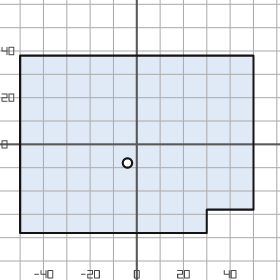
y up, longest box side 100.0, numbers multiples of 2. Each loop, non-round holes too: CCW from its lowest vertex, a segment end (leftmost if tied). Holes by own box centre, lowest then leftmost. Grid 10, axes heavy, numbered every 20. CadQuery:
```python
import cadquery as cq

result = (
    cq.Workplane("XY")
    .moveTo(-50.0, -38.0)
    .lineTo(30.0, -38.0)
    .lineTo(30.0, -28.0)
    .lineTo(50.0, -28.0)
    .lineTo(50.0, 38.0)
    .lineTo(-50.0, 38.0)
    .close()
    .moveTo(-4.0, -8.0)
    .circle(2.0)
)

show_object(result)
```